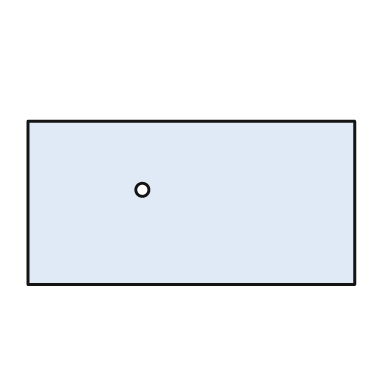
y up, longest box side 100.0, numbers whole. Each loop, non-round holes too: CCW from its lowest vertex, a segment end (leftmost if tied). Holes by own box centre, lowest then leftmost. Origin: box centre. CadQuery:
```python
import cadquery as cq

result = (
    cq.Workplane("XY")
    .moveTo(-50.0, -25.0)
    .lineTo(50.0, -25.0)
    .lineTo(50.0, 25.0)
    .lineTo(-50.0, 25.0)
    .close()
    .moveTo(-15.0, 4.0)
    .circle(2.0)
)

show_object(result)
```